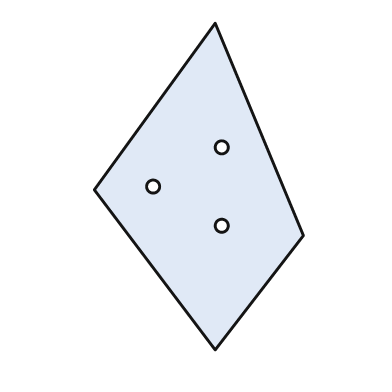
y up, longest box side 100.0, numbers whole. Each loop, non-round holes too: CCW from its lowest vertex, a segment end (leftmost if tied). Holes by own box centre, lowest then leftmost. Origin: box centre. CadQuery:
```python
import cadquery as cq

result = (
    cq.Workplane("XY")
    .moveTo(5.0, -50.0)
    .lineTo(32.0, -15.0)
    .lineTo(5.0, 50.0)
    .lineTo(-32.0, -1.0)
    .close()
    .moveTo(7.0, -12.0)
    .circle(2.0)
    .moveTo(-14.0, 0.0)
    .circle(2.0)
    .moveTo(7.0, 12.0)
    .circle(2.0)
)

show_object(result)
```